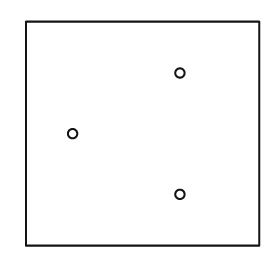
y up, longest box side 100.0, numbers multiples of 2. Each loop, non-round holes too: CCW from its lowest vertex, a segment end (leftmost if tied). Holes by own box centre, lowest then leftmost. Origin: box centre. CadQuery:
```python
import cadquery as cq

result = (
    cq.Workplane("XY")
    .moveTo(-50.0, -48.0)
    .lineTo(50.0, -48.0)
    .lineTo(50.0, 48.0)
    .lineTo(-50.0, 48.0)
    .close()
    .moveTo(16.0, -26.0)
    .circle(2.0)
    .moveTo(-30.0, 0.0)
    .circle(2.0)
    .moveTo(16.0, 26.0)
    .circle(2.0)
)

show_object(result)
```